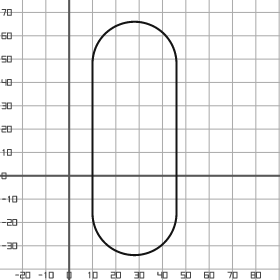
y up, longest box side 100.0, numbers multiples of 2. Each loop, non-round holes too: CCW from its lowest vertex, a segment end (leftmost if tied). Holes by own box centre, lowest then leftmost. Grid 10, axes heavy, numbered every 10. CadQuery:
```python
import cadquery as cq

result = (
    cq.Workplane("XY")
    .moveTo(10.0, -16.0)
    .threePointArc((28.0, -34.0), (46.0, -16.0))
    .lineTo(46.0, 48.0)
    .threePointArc((28.0, 66.0), (10.0, 48.0))
    .close()
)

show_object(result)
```